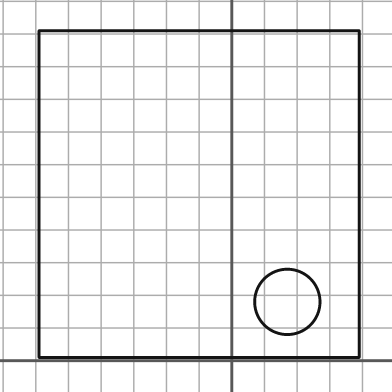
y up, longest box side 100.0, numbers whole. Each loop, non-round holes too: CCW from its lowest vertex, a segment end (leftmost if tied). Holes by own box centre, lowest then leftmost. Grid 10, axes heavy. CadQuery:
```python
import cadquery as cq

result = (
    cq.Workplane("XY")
    .moveTo(-59.0, 1.0)
    .lineTo(39.0, 1.0)
    .lineTo(39.0, 101.0)
    .lineTo(-59.0, 101.0)
    .close()
    .moveTo(17.0, 18.0)
    .circle(10.0)
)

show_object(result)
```